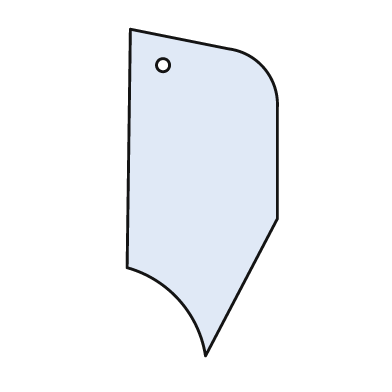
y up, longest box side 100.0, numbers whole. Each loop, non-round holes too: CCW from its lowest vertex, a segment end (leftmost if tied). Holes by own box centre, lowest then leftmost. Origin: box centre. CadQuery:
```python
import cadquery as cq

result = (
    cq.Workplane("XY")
    .moveTo(1.0, -50.0)
    .lineTo(23.0, -8.0)
    .lineTo(23.0, 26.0)
    .threePointArc((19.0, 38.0), (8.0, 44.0))
    .lineTo(-22.0, 50.0)
    .lineTo(-23.0, -23.0)
    .threePointArc((-7.0, -33.0), (1.0, -50.0))
    .close()
    .moveTo(-12.0, 39.0)
    .circle(2.0)
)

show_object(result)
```